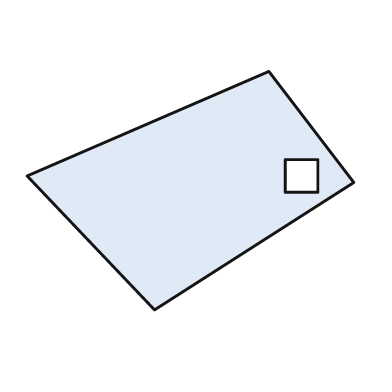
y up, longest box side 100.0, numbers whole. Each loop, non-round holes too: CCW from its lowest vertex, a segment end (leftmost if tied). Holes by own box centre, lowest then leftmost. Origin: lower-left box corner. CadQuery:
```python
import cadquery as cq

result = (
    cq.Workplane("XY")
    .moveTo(39.0, 0.0)
    .lineTo(100.0, 39.0)
    .lineTo(74.0, 73.0)
    .lineTo(0.0, 41.0)
    .close()
    .moveTo(79.0, 36.0)
    .lineTo(89.0, 36.0)
    .lineTo(89.0, 46.0)
    .lineTo(79.0, 46.0)
    .close()
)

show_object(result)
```